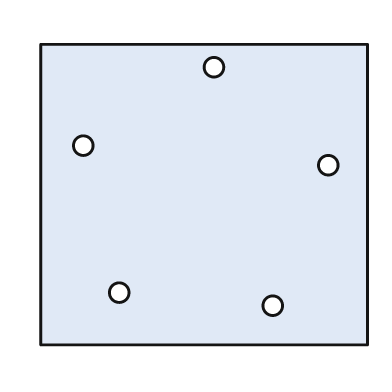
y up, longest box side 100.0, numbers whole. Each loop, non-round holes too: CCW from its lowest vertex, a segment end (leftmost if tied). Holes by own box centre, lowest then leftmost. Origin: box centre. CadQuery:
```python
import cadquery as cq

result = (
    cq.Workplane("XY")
    .moveTo(-50.0, -46.0)
    .lineTo(50.0, -46.0)
    .lineTo(50.0, 46.0)
    .lineTo(-50.0, 46.0)
    .close()
    .moveTo(21.0, -34.0)
    .circle(3.0)
    .moveTo(-26.0, -30.0)
    .circle(3.0)
    .moveTo(38.0, 9.0)
    .circle(3.0)
    .moveTo(-37.0, 15.0)
    .circle(3.0)
    .moveTo(3.0, 39.0)
    .circle(3.0)
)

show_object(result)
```